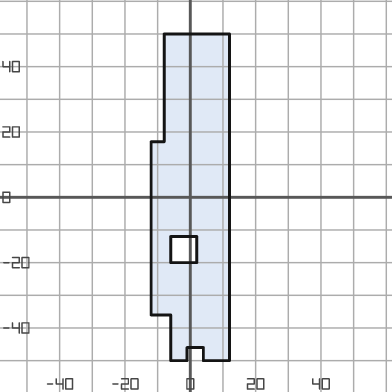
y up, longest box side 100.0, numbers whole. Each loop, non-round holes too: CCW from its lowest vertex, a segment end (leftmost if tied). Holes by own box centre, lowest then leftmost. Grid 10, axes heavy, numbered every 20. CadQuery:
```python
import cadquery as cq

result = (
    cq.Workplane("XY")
    .moveTo(-6.0, -50.0)
    .lineTo(-1.0, -50.0)
    .lineTo(-1.0, -46.0)
    .lineTo(4.0, -46.0)
    .lineTo(4.0, -50.0)
    .lineTo(12.0, -50.0)
    .lineTo(12.0, 50.0)
    .lineTo(-8.0, 50.0)
    .lineTo(-8.0, 17.0)
    .lineTo(-12.0, 17.0)
    .lineTo(-12.0, -36.0)
    .lineTo(-6.0, -36.0)
    .close()
    .moveTo(-6.0, -20.0)
    .lineTo(2.0, -20.0)
    .lineTo(2.0, -12.0)
    .lineTo(-6.0, -12.0)
    .close()
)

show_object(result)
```